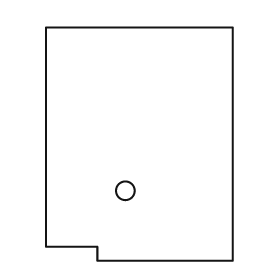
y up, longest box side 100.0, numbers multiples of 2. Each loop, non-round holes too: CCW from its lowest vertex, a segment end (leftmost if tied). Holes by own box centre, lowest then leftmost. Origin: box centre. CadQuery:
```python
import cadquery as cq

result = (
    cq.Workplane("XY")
    .moveTo(-18.0, -50.0)
    .lineTo(40.0, -50.0)
    .lineTo(40.0, 50.0)
    .lineTo(-40.0, 50.0)
    .lineTo(-40.0, -44.0)
    .lineTo(-18.0, -44.0)
    .close()
    .moveTo(-6.0, -20.0)
    .circle(4.0)
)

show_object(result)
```